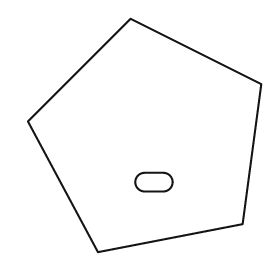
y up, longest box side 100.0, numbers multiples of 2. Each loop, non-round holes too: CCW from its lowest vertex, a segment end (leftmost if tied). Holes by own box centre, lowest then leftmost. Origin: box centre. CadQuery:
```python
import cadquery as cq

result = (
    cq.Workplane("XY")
    .moveTo(-20.0, -50.0)
    .lineTo(42.0, -38.0)
    .lineTo(50.0, 22.0)
    .lineTo(-6.0, 50.0)
    .lineTo(-50.0, 6.0)
    .close()
    .moveTo(0.0, -24.0)
    .lineTo(8.0, -24.0)
    .threePointArc((12.0, -20.0), (8.0, -16.0))
    .lineTo(0.0, -16.0)
    .threePointArc((-4.0, -20.0), (0.0, -24.0))
    .close()
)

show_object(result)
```